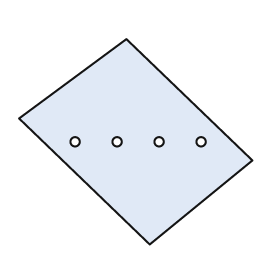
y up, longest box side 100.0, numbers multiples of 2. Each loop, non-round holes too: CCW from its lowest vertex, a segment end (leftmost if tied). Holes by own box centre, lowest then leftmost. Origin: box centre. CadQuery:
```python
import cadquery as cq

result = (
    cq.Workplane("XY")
    .moveTo(6.0, -44.0)
    .lineTo(50.0, -8.0)
    .lineTo(-4.0, 44.0)
    .lineTo(-50.0, 10.0)
    .close()
    .moveTo(-26.0, 0.0)
    .circle(2.0)
    .moveTo(-8.0, 0.0)
    .circle(2.0)
    .moveTo(10.0, 0.0)
    .circle(2.0)
    .moveTo(28.0, 0.0)
    .circle(2.0)
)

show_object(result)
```